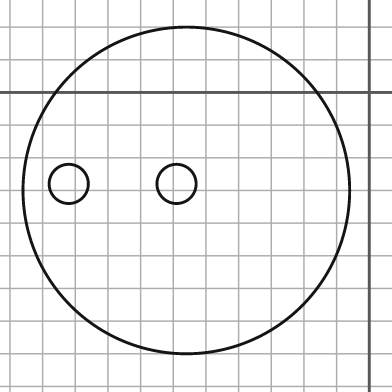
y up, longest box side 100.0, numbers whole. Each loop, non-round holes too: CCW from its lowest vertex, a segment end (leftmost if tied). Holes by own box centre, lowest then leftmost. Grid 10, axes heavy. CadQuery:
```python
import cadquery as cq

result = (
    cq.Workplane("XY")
    .moveTo(-56.0, -30.0)
    .circle(50.0)
    .moveTo(-92.0, -28.0)
    .circle(6.0)
    .moveTo(-59.0, -28.0)
    .circle(6.0)
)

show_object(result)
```